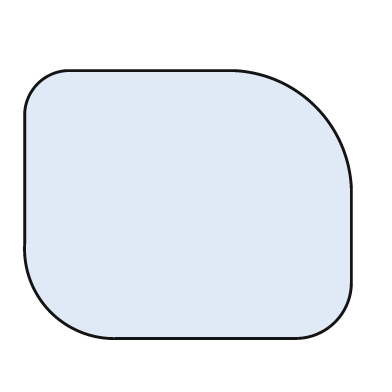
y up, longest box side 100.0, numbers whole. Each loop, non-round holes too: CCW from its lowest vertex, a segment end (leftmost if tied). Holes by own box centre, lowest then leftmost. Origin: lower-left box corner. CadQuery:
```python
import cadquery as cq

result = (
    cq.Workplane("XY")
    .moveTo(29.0, 0.0)
    .lineTo(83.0, 0.0)
    .threePointArc((95.0, 5.0), (100.0, 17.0))
    .lineTo(100.0, 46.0)
    .threePointArc((89.0, 71.0), (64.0, 82.0))
    .lineTo(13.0, 82.0)
    .threePointArc((4.0, 78.0), (0.0, 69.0))
    .lineTo(0.0, 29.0)
    .threePointArc((8.0, 8.0), (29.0, 0.0))
    .close()
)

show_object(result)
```